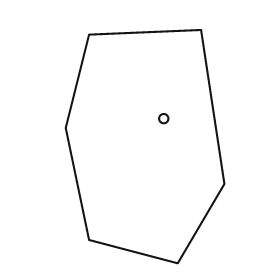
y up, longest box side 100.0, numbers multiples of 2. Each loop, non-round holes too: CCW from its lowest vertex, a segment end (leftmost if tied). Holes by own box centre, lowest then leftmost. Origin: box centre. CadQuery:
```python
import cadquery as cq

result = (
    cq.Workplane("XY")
    .moveTo(14.0, -50.0)
    .lineTo(34.0, -16.0)
    .lineTo(24.0, 50.0)
    .lineTo(-24.0, 48.0)
    .lineTo(-34.0, 8.0)
    .lineTo(-24.0, -40.0)
    .close()
    .moveTo(8.0, 12.0)
    .circle(2.0)
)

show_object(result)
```